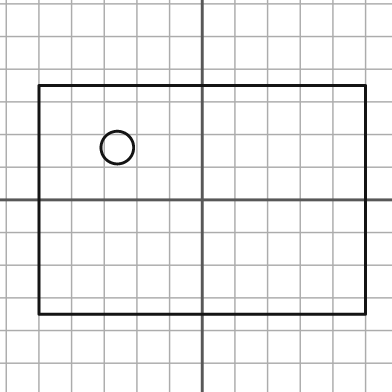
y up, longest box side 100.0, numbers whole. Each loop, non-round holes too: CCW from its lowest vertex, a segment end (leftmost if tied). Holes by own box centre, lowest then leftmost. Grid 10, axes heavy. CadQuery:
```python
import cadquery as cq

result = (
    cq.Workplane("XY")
    .moveTo(-50.0, -35.0)
    .lineTo(50.0, -35.0)
    .lineTo(50.0, 35.0)
    .lineTo(-50.0, 35.0)
    .close()
    .moveTo(-26.0, 16.0)
    .circle(5.0)
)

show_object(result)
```